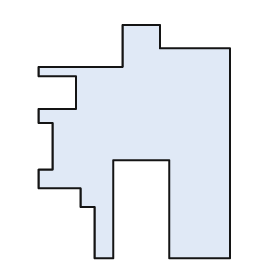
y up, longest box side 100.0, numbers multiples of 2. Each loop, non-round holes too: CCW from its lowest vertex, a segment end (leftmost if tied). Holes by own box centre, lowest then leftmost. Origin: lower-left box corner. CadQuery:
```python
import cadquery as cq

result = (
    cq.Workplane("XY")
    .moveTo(24.0, 0.0)
    .lineTo(32.0, 0.0)
    .lineTo(32.0, 42.0)
    .lineTo(56.0, 42.0)
    .lineTo(56.0, 0.0)
    .lineTo(82.0, 0.0)
    .lineTo(82.0, 90.0)
    .lineTo(52.0, 90.0)
    .lineTo(52.0, 100.0)
    .lineTo(36.0, 100.0)
    .lineTo(36.0, 82.0)
    .lineTo(0.0, 82.0)
    .lineTo(0.0, 78.0)
    .lineTo(16.0, 78.0)
    .lineTo(16.0, 64.0)
    .lineTo(0.0, 64.0)
    .lineTo(0.0, 58.0)
    .lineTo(6.0, 58.0)
    .lineTo(6.0, 38.0)
    .lineTo(0.0, 38.0)
    .lineTo(0.0, 30.0)
    .lineTo(18.0, 30.0)
    .lineTo(18.0, 22.0)
    .lineTo(24.0, 22.0)
    .close()
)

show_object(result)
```